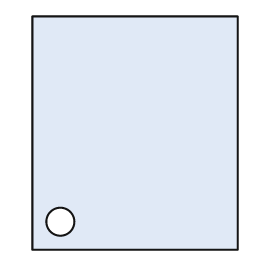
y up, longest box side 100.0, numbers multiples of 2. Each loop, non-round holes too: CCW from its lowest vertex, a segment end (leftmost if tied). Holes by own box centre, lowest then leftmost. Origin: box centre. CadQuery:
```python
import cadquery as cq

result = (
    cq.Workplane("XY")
    .moveTo(-44.0, -50.0)
    .lineTo(44.0, -50.0)
    .lineTo(44.0, 50.0)
    .lineTo(-44.0, 50.0)
    .close()
    .moveTo(-32.0, -38.0)
    .circle(6.0)
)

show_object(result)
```